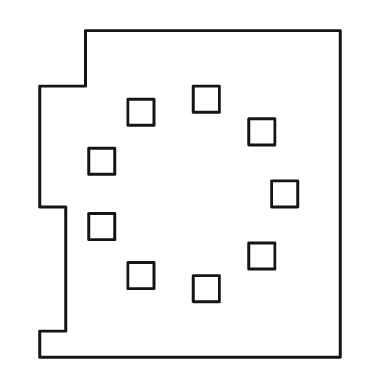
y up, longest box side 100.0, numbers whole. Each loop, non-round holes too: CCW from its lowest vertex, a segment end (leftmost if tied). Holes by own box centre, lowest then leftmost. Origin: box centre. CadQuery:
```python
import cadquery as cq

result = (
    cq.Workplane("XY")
    .moveTo(-46.0, -50.0)
    .lineTo(46.0, -50.0)
    .lineTo(46.0, 50.0)
    .lineTo(-32.0, 50.0)
    .lineTo(-32.0, 33.0)
    .lineTo(-46.0, 33.0)
    .lineTo(-46.0, -4.0)
    .lineTo(-38.0, -4.0)
    .lineTo(-38.0, -42.0)
    .lineTo(-46.0, -42.0)
    .close()
    .moveTo(1.0, -33.0)
    .lineTo(9.0, -33.0)
    .lineTo(9.0, -25.0)
    .lineTo(1.0, -25.0)
    .close()
    .moveTo(-19.0, -29.0)
    .lineTo(-11.0, -29.0)
    .lineTo(-11.0, -21.0)
    .lineTo(-19.0, -21.0)
    .close()
    .moveTo(18.0, -23.0)
    .lineTo(26.0, -23.0)
    .lineTo(26.0, -15.0)
    .lineTo(18.0, -15.0)
    .close()
    .moveTo(-31.0, -14.0)
    .lineTo(-23.0, -14.0)
    .lineTo(-23.0, -6.0)
    .lineTo(-31.0, -6.0)
    .close()
    .moveTo(25.0, -4.0)
    .lineTo(33.0, -4.0)
    .lineTo(33.0, 4.0)
    .lineTo(25.0, 4.0)
    .close()
    .moveTo(-31.0, 6.0)
    .lineTo(-23.0, 6.0)
    .lineTo(-23.0, 14.0)
    .lineTo(-31.0, 14.0)
    .close()
    .moveTo(18.0, 15.0)
    .lineTo(26.0, 15.0)
    .lineTo(26.0, 23.0)
    .lineTo(18.0, 23.0)
    .close()
    .moveTo(-19.0, 21.0)
    .lineTo(-11.0, 21.0)
    .lineTo(-11.0, 29.0)
    .lineTo(-19.0, 29.0)
    .close()
    .moveTo(1.0, 25.0)
    .lineTo(9.0, 25.0)
    .lineTo(9.0, 33.0)
    .lineTo(1.0, 33.0)
    .close()
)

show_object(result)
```